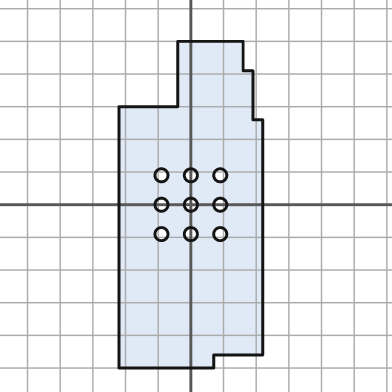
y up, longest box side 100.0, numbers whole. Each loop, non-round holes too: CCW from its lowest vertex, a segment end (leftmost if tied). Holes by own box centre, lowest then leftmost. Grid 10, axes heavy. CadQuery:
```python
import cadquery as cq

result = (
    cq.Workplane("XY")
    .moveTo(-22.0, -50.0)
    .lineTo(7.0, -50.0)
    .lineTo(7.0, -46.0)
    .lineTo(22.0, -46.0)
    .lineTo(22.0, 26.0)
    .lineTo(19.0, 26.0)
    .lineTo(19.0, 41.0)
    .lineTo(16.0, 41.0)
    .lineTo(16.0, 50.0)
    .lineTo(-4.0, 50.0)
    .lineTo(-4.0, 30.0)
    .lineTo(-22.0, 30.0)
    .close()
    .moveTo(-9.0, -9.0)
    .circle(2.0)
    .moveTo(0.0, -9.0)
    .circle(2.0)
    .moveTo(9.0, -9.0)
    .circle(2.0)
    .moveTo(-9.0, 0.0)
    .circle(2.0)
    .moveTo(0.0, 0.0)
    .circle(2.0)
    .moveTo(9.0, 0.0)
    .circle(2.0)
    .moveTo(-9.0, 9.0)
    .circle(2.0)
    .moveTo(0.0, 9.0)
    .circle(2.0)
    .moveTo(9.0, 9.0)
    .circle(2.0)
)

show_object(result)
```